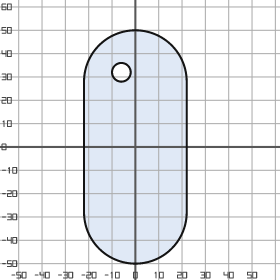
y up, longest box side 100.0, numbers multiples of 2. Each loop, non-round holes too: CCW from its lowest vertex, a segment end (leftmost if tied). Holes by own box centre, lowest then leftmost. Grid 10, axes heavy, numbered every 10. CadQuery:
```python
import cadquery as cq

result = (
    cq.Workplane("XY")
    .moveTo(-22.0, -28.0)
    .threePointArc((0.0, -50.0), (22.0, -28.0))
    .lineTo(22.0, 28.0)
    .threePointArc((0.0, 50.0), (-22.0, 28.0))
    .close()
    .moveTo(-6.0, 32.0)
    .circle(4.0)
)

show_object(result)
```